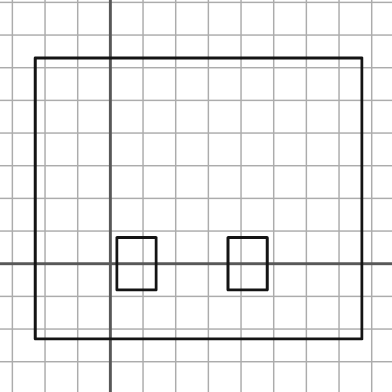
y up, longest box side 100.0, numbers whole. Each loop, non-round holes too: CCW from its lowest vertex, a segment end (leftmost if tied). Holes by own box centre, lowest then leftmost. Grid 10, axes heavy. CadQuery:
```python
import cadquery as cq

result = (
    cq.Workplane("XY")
    .moveTo(-23.0, -23.0)
    .lineTo(77.0, -23.0)
    .lineTo(77.0, 63.0)
    .lineTo(-23.0, 63.0)
    .close()
    .moveTo(2.0, -8.0)
    .lineTo(14.0, -8.0)
    .lineTo(14.0, 8.0)
    .lineTo(2.0, 8.0)
    .close()
    .moveTo(36.0, -8.0)
    .lineTo(48.0, -8.0)
    .lineTo(48.0, 8.0)
    .lineTo(36.0, 8.0)
    .close()
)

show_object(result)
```